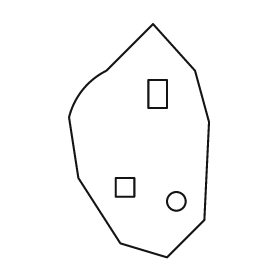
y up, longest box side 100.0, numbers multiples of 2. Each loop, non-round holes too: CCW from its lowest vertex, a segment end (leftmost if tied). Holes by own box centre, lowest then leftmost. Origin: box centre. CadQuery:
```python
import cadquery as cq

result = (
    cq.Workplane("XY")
    .moveTo(12.0, -50.0)
    .lineTo(28.0, -34.0)
    .lineTo(30.0, 8.0)
    .lineTo(24.0, 30.0)
    .lineTo(6.0, 50.0)
    .lineTo(-14.0, 30.0)
    .threePointArc((-24.0, 22.0), (-30.0, 10.0))
    .lineTo(-26.0, -16.0)
    .lineTo(-8.0, -44.0)
    .close()
    .moveTo(16.0, -26.0)
    .circle(4.0)
    .moveTo(-10.0, -24.0)
    .lineTo(-2.0, -24.0)
    .lineTo(-2.0, -16.0)
    .lineTo(-10.0, -16.0)
    .close()
    .moveTo(4.0, 14.0)
    .lineTo(12.0, 14.0)
    .lineTo(12.0, 26.0)
    .lineTo(4.0, 26.0)
    .close()
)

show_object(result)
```